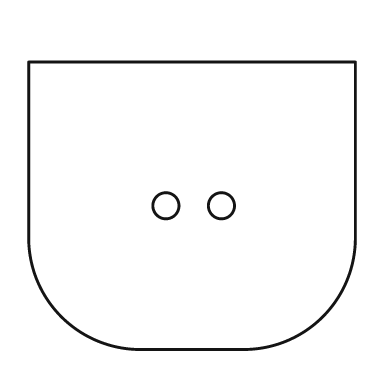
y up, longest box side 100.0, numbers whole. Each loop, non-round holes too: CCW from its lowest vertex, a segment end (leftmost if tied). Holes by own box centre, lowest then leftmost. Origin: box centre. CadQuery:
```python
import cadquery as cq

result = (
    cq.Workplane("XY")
    .moveTo(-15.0, -44.0)
    .lineTo(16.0, -44.0)
    .threePointArc((40.0, -34.0), (50.0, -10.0))
    .lineTo(50.0, 44.0)
    .lineTo(-50.0, 44.0)
    .lineTo(-50.0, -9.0)
    .threePointArc((-40.0, -34.0), (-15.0, -44.0))
    .close()
    .moveTo(-8.0, 0.0)
    .circle(4.0)
    .moveTo(9.0, 0.0)
    .circle(4.0)
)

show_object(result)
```